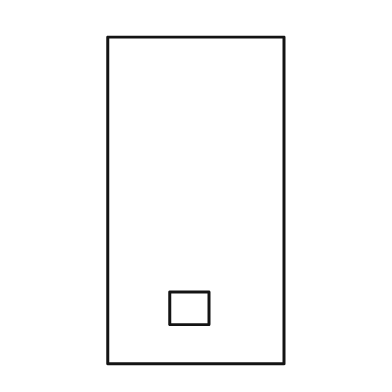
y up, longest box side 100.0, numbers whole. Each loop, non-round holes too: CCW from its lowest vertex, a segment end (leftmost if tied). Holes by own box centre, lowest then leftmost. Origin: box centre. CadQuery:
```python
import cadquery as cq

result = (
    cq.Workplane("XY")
    .moveTo(-27.0, -50.0)
    .lineTo(27.0, -50.0)
    .lineTo(27.0, 50.0)
    .lineTo(-27.0, 50.0)
    .close()
    .moveTo(-8.0, -38.0)
    .lineTo(4.0, -38.0)
    .lineTo(4.0, -28.0)
    .lineTo(-8.0, -28.0)
    .close()
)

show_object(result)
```